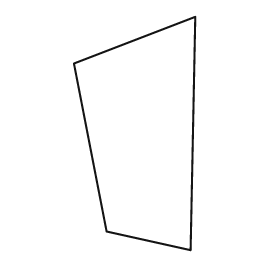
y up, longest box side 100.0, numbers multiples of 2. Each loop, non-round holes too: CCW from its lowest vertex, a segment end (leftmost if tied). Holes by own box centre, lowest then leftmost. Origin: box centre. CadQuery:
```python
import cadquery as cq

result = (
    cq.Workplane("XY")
    .moveTo(24.0, -50.0)
    .lineTo(26.0, 50.0)
    .lineTo(-26.0, 30.0)
    .lineTo(-12.0, -42.0)
    .close()
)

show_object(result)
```